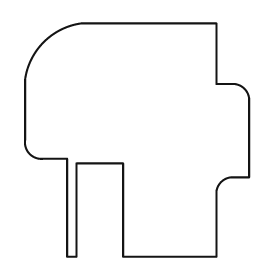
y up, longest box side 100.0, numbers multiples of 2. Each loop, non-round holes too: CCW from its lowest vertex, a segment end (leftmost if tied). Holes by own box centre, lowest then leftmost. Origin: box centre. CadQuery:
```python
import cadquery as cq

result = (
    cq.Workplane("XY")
    .moveTo(-30.0, -50.0)
    .lineTo(-26.0, -50.0)
    .lineTo(-26.0, -10.0)
    .lineTo(-6.0, -10.0)
    .lineTo(-6.0, -50.0)
    .lineTo(34.0, -50.0)
    .lineTo(34.0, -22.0)
    .threePointArc((36.0, -18.0), (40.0, -16.0))
    .lineTo(48.0, -16.0)
    .lineTo(48.0, 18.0)
    .threePointArc((46.0, 22.0), (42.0, 24.0))
    .lineTo(34.0, 24.0)
    .lineTo(34.0, 50.0)
    .lineTo(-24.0, 50.0)
    .threePointArc((-40.0, 42.0), (-48.0, 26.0))
    .lineTo(-48.0, 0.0)
    .threePointArc((-46.0, -6.0), (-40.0, -8.0))
    .lineTo(-30.0, -8.0)
    .close()
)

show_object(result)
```